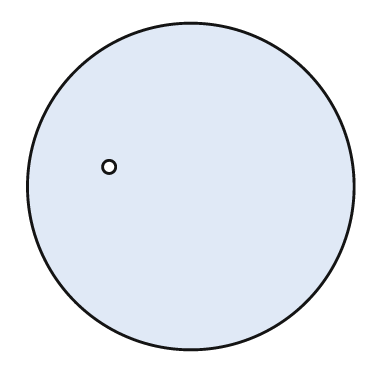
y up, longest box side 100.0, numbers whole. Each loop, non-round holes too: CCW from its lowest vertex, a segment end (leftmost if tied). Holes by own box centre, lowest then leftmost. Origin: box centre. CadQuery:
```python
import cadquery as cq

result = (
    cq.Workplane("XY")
    .moveTo(0.0, 0.0)
    .circle(50.0)
    .moveTo(-25.0, 6.0)
    .circle(2.0)
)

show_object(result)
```